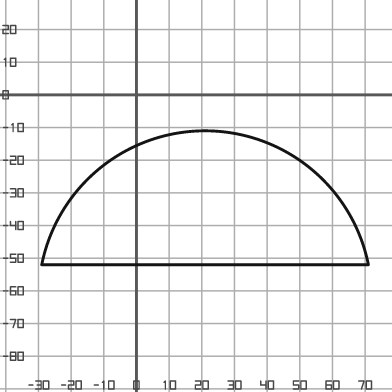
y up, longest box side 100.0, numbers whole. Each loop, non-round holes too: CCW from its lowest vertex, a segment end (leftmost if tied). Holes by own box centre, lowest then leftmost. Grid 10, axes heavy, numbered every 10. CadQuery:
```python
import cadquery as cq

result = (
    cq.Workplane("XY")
    .moveTo(-29.0, -52.0)
    .lineTo(71.0, -52.0)
    .threePointArc((21.0, -11.0), (-29.0, -52.0))
    .close()
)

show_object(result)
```